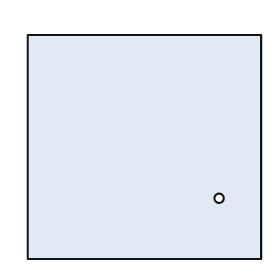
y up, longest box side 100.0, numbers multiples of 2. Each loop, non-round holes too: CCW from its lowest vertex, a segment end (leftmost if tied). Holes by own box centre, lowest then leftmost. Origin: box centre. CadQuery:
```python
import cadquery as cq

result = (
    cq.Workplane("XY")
    .moveTo(-50.0, -48.0)
    .lineTo(50.0, -48.0)
    .lineTo(50.0, 48.0)
    .lineTo(-50.0, 48.0)
    .close()
    .moveTo(32.0, -22.0)
    .circle(2.0)
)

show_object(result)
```